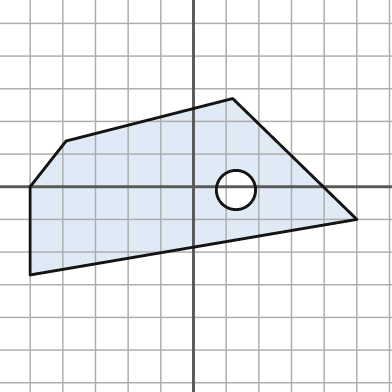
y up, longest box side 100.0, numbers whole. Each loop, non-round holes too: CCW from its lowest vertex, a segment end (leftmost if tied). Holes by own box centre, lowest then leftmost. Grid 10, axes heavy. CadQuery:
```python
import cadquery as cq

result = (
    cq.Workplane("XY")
    .moveTo(-50.0, -27.0)
    .lineTo(50.0, -10.0)
    .lineTo(12.0, 27.0)
    .lineTo(-39.0, 14.0)
    .lineTo(-50.0, 0.0)
    .close()
    .moveTo(13.0, -1.0)
    .circle(6.0)
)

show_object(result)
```